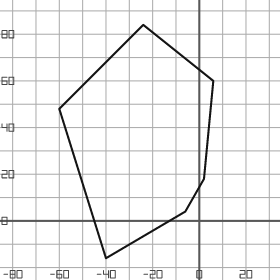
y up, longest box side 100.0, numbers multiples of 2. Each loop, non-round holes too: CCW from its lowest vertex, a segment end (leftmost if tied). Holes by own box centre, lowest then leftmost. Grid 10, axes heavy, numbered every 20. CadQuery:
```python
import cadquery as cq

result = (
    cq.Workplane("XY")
    .moveTo(-40.0, -16.0)
    .lineTo(-6.0, 4.0)
    .lineTo(2.0, 18.0)
    .lineTo(6.0, 60.0)
    .lineTo(-24.0, 84.0)
    .lineTo(-60.0, 48.0)
    .close()
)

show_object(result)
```